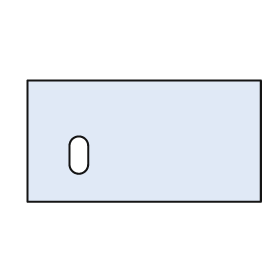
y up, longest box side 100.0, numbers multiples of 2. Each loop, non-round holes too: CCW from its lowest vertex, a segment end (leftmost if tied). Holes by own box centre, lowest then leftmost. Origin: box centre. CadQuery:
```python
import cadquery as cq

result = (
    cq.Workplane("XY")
    .moveTo(-50.0, -26.0)
    .lineTo(50.0, -26.0)
    .lineTo(50.0, 26.0)
    .lineTo(-50.0, 26.0)
    .close()
    .moveTo(-32.0, -10.0)
    .threePointArc((-28.0, -14.0), (-24.0, -10.0))
    .lineTo(-24.0, -2.0)
    .threePointArc((-28.0, 2.0), (-32.0, -2.0))
    .close()
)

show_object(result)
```